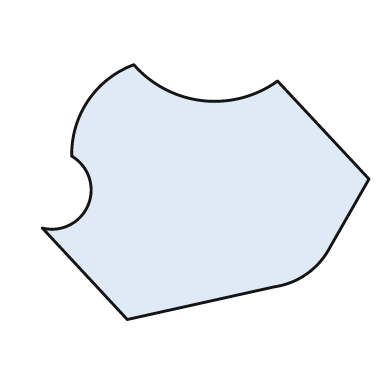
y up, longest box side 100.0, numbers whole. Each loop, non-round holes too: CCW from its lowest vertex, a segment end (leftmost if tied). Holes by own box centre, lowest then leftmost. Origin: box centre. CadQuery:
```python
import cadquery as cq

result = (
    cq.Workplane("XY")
    .moveTo(-24.0, -39.0)
    .lineTo(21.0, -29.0)
    .threePointArc((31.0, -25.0), (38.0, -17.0))
    .lineTo(50.0, 4.0)
    .lineTo(22.0, 34.0)
    .threePointArc((-1.0, 28.0), (-22.0, 39.0))
    .threePointArc((-36.0, 28.0), (-41.0, 11.0))
    .threePointArc((-36.0, -4.0), (-50.0, -11.0))
    .close()
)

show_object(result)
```